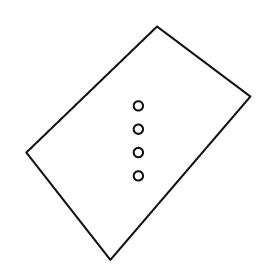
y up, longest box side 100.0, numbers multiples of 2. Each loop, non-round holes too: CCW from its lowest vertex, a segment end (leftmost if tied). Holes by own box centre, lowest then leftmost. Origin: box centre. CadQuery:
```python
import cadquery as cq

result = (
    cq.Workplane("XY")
    .moveTo(-12.0, -50.0)
    .lineTo(48.0, 20.0)
    .lineTo(8.0, 50.0)
    .lineTo(-48.0, -4.0)
    .close()
    .moveTo(0.0, -14.0)
    .circle(2.0)
    .moveTo(0.0, -4.0)
    .circle(2.0)
    .moveTo(0.0, 6.0)
    .circle(2.0)
    .moveTo(0.0, 16.0)
    .circle(2.0)
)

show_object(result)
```